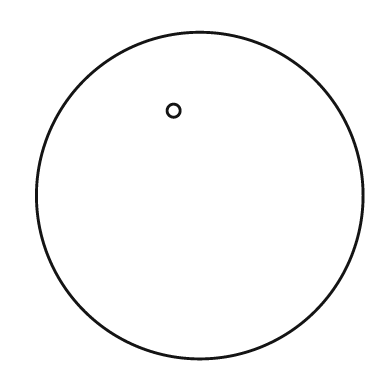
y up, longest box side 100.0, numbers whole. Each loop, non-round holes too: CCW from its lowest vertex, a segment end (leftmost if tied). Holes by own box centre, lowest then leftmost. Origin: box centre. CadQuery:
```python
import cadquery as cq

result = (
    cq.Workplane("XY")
    .moveTo(0.0, 0.0)
    .circle(50.0)
    .moveTo(-8.0, 26.0)
    .circle(2.0)
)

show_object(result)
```